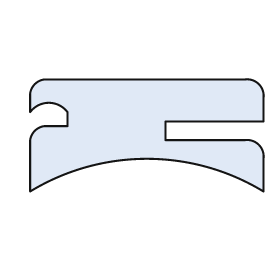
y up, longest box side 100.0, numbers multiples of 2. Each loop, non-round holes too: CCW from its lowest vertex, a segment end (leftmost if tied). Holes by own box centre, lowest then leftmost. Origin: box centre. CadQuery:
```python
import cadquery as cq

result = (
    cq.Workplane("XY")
    .moveTo(-50.0, -24.0)
    .threePointArc((0.0, -10.0), (50.0, -24.0))
    .lineTo(50.0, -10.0)
    .threePointArc((48.0, -4.0), (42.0, -2.0))
    .lineTo(8.0, -2.0)
    .lineTo(8.0, 6.0)
    .lineTo(50.0, 6.0)
    .lineTo(50.0, 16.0)
    .threePointArc((48.0, 22.0), (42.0, 24.0))
    .lineTo(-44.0, 24.0)
    .threePointArc((-48.0, 22.0), (-50.0, 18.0))
    .lineTo(-50.0, 10.0)
    .threePointArc((-42.0, 14.0), (-34.0, 10.0))
    .lineTo(-34.0, 4.0)
    .lineTo(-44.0, 4.0)
    .threePointArc((-48.0, 2.0), (-50.0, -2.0))
    .close()
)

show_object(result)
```